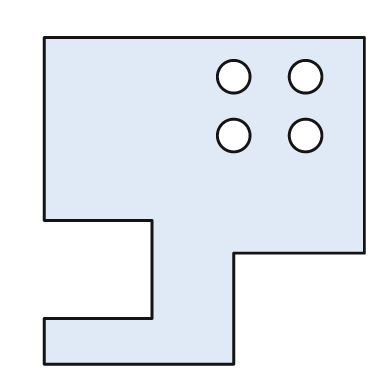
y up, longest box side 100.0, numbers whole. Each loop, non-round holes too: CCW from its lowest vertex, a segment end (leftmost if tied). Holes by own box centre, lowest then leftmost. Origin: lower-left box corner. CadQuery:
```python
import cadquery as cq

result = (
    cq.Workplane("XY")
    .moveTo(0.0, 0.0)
    .lineTo(58.0, 0.0)
    .lineTo(58.0, 34.0)
    .lineTo(98.0, 34.0)
    .lineTo(98.0, 100.0)
    .lineTo(0.0, 100.0)
    .lineTo(0.0, 44.0)
    .lineTo(33.0, 44.0)
    .lineTo(33.0, 14.0)
    .lineTo(0.0, 14.0)
    .close()
    .moveTo(58.0, 70.0)
    .circle(5.0)
    .moveTo(80.0, 70.0)
    .circle(5.0)
    .moveTo(58.0, 88.0)
    .circle(5.0)
    .moveTo(80.0, 88.0)
    .circle(5.0)
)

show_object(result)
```